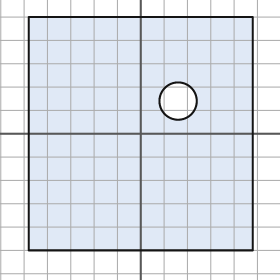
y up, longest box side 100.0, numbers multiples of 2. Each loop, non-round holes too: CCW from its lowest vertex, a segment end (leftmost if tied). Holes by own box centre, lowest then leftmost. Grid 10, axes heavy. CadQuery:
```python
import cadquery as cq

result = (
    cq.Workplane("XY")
    .moveTo(-48.0, -50.0)
    .lineTo(48.0, -50.0)
    .lineTo(48.0, 50.0)
    .lineTo(-48.0, 50.0)
    .close()
    .moveTo(16.0, 14.0)
    .circle(8.0)
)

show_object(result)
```